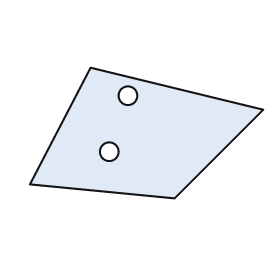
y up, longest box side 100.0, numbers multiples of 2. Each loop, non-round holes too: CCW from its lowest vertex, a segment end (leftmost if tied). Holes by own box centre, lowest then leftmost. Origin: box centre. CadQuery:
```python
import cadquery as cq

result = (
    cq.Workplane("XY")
    .moveTo(12.0, -28.0)
    .lineTo(50.0, 10.0)
    .lineTo(-24.0, 28.0)
    .lineTo(-50.0, -22.0)
    .close()
    .moveTo(-16.0, -8.0)
    .circle(4.0)
    .moveTo(-8.0, 16.0)
    .circle(4.0)
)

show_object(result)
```